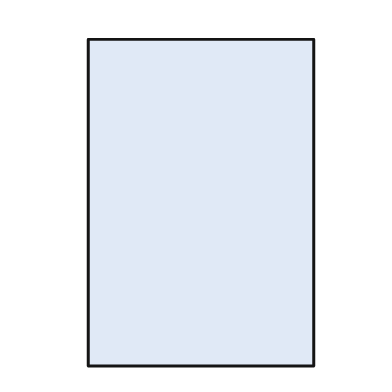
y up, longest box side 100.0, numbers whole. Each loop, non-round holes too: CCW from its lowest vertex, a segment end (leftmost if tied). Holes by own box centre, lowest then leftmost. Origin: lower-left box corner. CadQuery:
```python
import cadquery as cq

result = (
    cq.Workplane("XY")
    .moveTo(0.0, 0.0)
    .lineTo(69.0, 0.0)
    .lineTo(69.0, 100.0)
    .lineTo(0.0, 100.0)
    .close()
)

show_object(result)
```